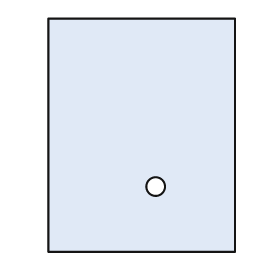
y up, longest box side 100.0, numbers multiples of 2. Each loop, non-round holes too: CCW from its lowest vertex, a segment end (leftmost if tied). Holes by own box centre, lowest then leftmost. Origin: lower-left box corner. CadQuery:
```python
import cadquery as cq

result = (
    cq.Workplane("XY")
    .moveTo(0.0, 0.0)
    .lineTo(80.0, 0.0)
    .lineTo(80.0, 100.0)
    .lineTo(0.0, 100.0)
    .close()
    .moveTo(46.0, 28.0)
    .circle(4.0)
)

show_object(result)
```